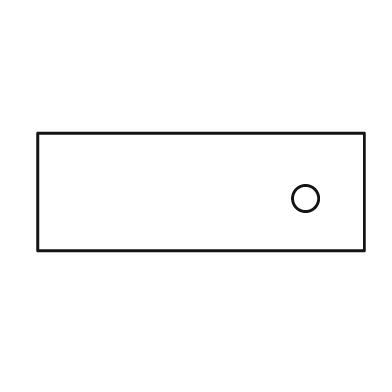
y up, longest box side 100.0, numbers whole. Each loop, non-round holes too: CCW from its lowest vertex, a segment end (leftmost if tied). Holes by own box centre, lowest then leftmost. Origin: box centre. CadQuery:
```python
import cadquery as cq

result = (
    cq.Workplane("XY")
    .moveTo(-50.0, -18.0)
    .lineTo(50.0, -18.0)
    .lineTo(50.0, 18.0)
    .lineTo(-50.0, 18.0)
    .close()
    .moveTo(32.0, -2.0)
    .circle(4.0)
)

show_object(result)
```